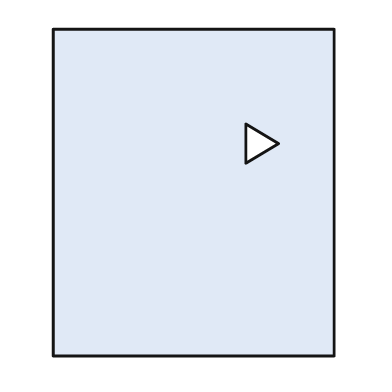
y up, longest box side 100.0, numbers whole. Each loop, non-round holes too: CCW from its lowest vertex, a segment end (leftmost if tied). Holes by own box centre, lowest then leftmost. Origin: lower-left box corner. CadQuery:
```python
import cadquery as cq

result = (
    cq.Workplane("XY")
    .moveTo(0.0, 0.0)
    .lineTo(86.0, 0.0)
    .lineTo(86.0, 100.0)
    .lineTo(0.0, 100.0)
    .close()
    .moveTo(59.0, 59.0)
    .lineTo(69.0, 65.0)
    .lineTo(59.0, 71.0)
    .close()
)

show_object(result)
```